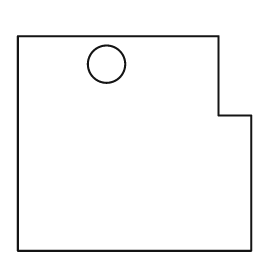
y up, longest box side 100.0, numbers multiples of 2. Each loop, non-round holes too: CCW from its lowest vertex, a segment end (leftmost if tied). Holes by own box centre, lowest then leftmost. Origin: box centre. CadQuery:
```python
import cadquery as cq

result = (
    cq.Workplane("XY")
    .moveTo(-50.0, -46.0)
    .lineTo(50.0, -46.0)
    .lineTo(50.0, 12.0)
    .lineTo(36.0, 12.0)
    .lineTo(36.0, 46.0)
    .lineTo(-50.0, 46.0)
    .close()
    .moveTo(-12.0, 34.0)
    .circle(8.0)
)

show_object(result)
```